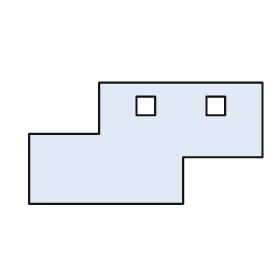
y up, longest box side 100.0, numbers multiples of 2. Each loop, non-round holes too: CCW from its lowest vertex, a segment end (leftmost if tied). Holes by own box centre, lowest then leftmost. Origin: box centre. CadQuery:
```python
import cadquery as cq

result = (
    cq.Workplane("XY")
    .moveTo(-50.0, -26.0)
    .lineTo(16.0, -26.0)
    .lineTo(16.0, -6.0)
    .lineTo(50.0, -6.0)
    .lineTo(50.0, 26.0)
    .lineTo(-20.0, 26.0)
    .lineTo(-20.0, 4.0)
    .lineTo(-50.0, 4.0)
    .close()
    .moveTo(-4.0, 12.0)
    .lineTo(4.0, 12.0)
    .lineTo(4.0, 20.0)
    .lineTo(-4.0, 20.0)
    .close()
    .moveTo(26.0, 12.0)
    .lineTo(34.0, 12.0)
    .lineTo(34.0, 20.0)
    .lineTo(26.0, 20.0)
    .close()
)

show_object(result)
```